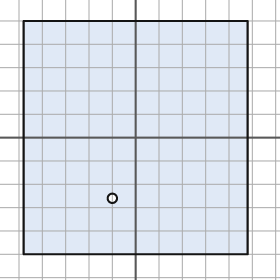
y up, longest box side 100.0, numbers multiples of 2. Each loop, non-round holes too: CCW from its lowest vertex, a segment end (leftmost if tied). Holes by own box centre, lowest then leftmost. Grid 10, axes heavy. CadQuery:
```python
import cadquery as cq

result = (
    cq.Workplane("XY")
    .moveTo(-48.0, -50.0)
    .lineTo(48.0, -50.0)
    .lineTo(48.0, 50.0)
    .lineTo(-48.0, 50.0)
    .close()
    .moveTo(-10.0, -26.0)
    .circle(2.0)
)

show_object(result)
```